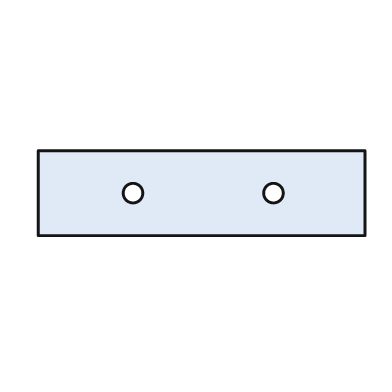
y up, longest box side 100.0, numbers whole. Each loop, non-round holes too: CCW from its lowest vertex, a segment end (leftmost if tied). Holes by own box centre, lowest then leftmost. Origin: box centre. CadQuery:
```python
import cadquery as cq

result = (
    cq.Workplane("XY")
    .moveTo(-50.0, -13.0)
    .lineTo(50.0, -13.0)
    .lineTo(50.0, 13.0)
    .lineTo(-50.0, 13.0)
    .close()
    .moveTo(-21.0, 0.0)
    .circle(3.0)
    .moveTo(22.0, 0.0)
    .circle(3.0)
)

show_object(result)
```